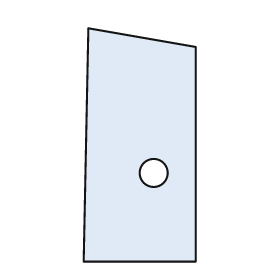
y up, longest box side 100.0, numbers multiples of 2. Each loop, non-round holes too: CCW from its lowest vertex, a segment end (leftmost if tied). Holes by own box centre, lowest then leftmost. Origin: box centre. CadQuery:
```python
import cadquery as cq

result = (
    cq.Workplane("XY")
    .moveTo(-24.0, -50.0)
    .lineTo(24.0, -50.0)
    .lineTo(24.0, 42.0)
    .lineTo(-22.0, 50.0)
    .close()
    .moveTo(6.0, -12.0)
    .circle(6.0)
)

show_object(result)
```